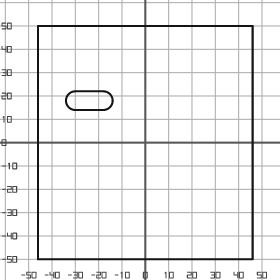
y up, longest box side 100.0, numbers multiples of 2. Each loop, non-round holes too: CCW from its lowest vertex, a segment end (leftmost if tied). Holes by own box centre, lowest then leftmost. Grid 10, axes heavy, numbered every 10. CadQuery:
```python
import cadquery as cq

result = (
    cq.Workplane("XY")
    .moveTo(-46.0, -50.0)
    .lineTo(46.0, -50.0)
    .lineTo(46.0, 50.0)
    .lineTo(-46.0, 50.0)
    .close()
    .moveTo(-30.0, 14.0)
    .lineTo(-18.0, 14.0)
    .threePointArc((-14.0, 18.0), (-18.0, 22.0))
    .lineTo(-30.0, 22.0)
    .threePointArc((-34.0, 18.0), (-30.0, 14.0))
    .close()
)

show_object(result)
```